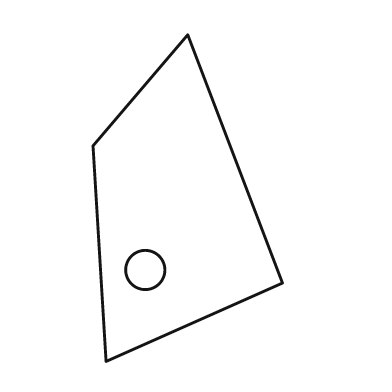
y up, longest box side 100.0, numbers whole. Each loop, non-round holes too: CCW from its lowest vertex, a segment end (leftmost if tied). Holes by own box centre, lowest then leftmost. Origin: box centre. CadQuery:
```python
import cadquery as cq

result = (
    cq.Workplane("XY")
    .moveTo(-25.0, -50.0)
    .lineTo(29.0, -26.0)
    .lineTo(0.0, 50.0)
    .lineTo(-29.0, 16.0)
    .close()
    .moveTo(-13.0, -22.0)
    .circle(6.0)
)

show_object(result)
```